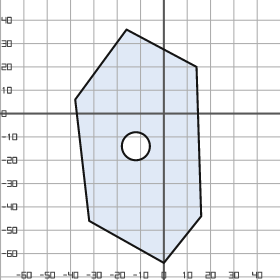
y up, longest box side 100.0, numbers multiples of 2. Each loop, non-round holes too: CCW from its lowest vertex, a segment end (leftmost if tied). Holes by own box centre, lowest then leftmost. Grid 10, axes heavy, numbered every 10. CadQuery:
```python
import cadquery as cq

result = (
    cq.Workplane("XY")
    .moveTo(0.0, -64.0)
    .lineTo(16.0, -44.0)
    .lineTo(14.0, 20.0)
    .lineTo(-16.0, 36.0)
    .lineTo(-38.0, 6.0)
    .lineTo(-32.0, -46.0)
    .close()
    .moveTo(-12.0, -14.0)
    .circle(6.0)
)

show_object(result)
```